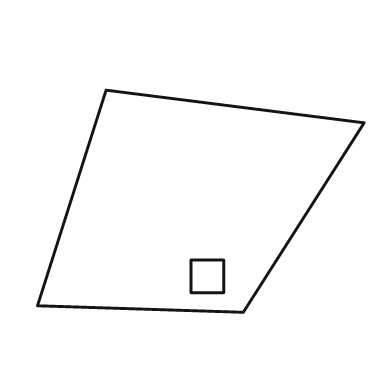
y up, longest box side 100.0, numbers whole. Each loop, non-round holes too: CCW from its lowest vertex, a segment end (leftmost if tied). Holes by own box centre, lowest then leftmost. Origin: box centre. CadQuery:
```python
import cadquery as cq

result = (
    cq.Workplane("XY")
    .moveTo(13.0, -34.0)
    .lineTo(50.0, 24.0)
    .lineTo(-29.0, 34.0)
    .lineTo(-50.0, -32.0)
    .close()
    .moveTo(-3.0, -28.0)
    .lineTo(7.0, -28.0)
    .lineTo(7.0, -18.0)
    .lineTo(-3.0, -18.0)
    .close()
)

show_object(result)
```